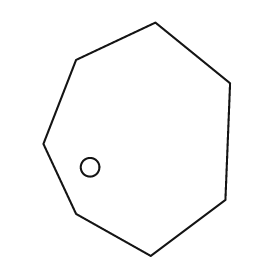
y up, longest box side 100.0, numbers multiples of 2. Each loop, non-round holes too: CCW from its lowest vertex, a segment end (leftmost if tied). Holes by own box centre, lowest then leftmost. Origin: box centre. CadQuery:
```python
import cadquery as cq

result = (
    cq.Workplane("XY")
    .moveTo(6.0, -50.0)
    .lineTo(38.0, -26.0)
    .lineTo(40.0, 24.0)
    .lineTo(8.0, 50.0)
    .lineTo(-26.0, 34.0)
    .lineTo(-40.0, -2.0)
    .lineTo(-26.0, -32.0)
    .close()
    .moveTo(-20.0, -12.0)
    .circle(4.0)
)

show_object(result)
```